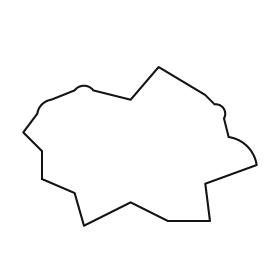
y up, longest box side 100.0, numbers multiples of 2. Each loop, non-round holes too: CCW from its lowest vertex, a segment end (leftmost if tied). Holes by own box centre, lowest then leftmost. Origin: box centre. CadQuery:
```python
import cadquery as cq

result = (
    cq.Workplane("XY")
    .moveTo(-24.0, -34.0)
    .lineTo(-4.0, -24.0)
    .lineTo(12.0, -32.0)
    .lineTo(30.0, -32.0)
    .lineTo(28.0, -16.0)
    .lineTo(50.0, -8.0)
    .threePointArc((46.0, 0.0), (38.0, 4.0))
    .lineTo(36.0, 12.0)
    .threePointArc((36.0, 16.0), (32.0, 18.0))
    .lineTo(28.0, 22.0)
    .lineTo(8.0, 34.0)
    .lineTo(-4.0, 20.0)
    .lineTo(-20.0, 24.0)
    .threePointArc((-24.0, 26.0), (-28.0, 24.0))
    .lineTo(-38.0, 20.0)
    .threePointArc((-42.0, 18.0), (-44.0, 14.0))
    .lineTo(-50.0, 6.0)
    .lineTo(-42.0, -2.0)
    .lineTo(-42.0, -14.0)
    .lineTo(-28.0, -20.0)
    .close()
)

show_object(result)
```